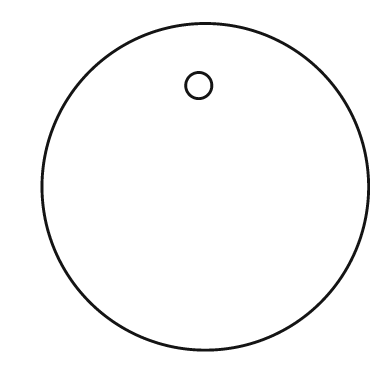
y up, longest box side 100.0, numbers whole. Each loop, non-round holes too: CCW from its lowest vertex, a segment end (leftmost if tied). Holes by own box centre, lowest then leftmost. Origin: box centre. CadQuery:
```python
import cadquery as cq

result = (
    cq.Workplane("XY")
    .moveTo(0.0, 0.0)
    .circle(50.0)
    .moveTo(-2.0, 31.0)
    .circle(4.0)
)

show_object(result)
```